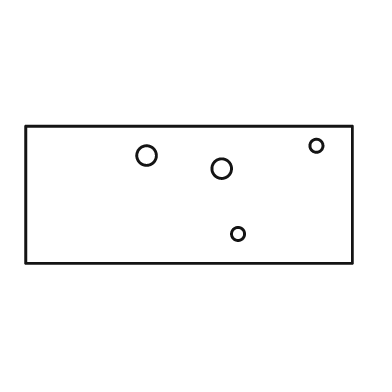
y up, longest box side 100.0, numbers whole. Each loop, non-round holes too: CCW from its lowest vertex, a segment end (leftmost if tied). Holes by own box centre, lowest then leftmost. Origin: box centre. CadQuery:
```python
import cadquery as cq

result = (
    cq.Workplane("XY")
    .moveTo(-50.0, -21.0)
    .lineTo(50.0, -21.0)
    .lineTo(50.0, 21.0)
    .lineTo(-50.0, 21.0)
    .close()
    .moveTo(15.0, -12.0)
    .circle(2.0)
    .moveTo(10.0, 8.0)
    .circle(3.0)
    .moveTo(-13.0, 12.0)
    .circle(3.0)
    .moveTo(39.0, 15.0)
    .circle(2.0)
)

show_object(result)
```